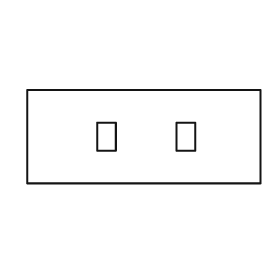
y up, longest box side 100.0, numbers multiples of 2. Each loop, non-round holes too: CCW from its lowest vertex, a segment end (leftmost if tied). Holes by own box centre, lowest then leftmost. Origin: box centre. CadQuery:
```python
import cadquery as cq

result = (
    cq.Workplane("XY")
    .moveTo(-50.0, -20.0)
    .lineTo(50.0, -20.0)
    .lineTo(50.0, 20.0)
    .lineTo(-50.0, 20.0)
    .close()
    .moveTo(-20.0, -6.0)
    .lineTo(-12.0, -6.0)
    .lineTo(-12.0, 6.0)
    .lineTo(-20.0, 6.0)
    .close()
    .moveTo(14.0, -6.0)
    .lineTo(22.0, -6.0)
    .lineTo(22.0, 6.0)
    .lineTo(14.0, 6.0)
    .close()
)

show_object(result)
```